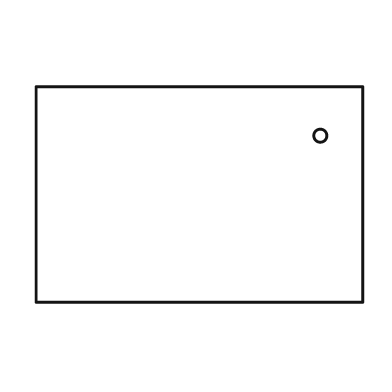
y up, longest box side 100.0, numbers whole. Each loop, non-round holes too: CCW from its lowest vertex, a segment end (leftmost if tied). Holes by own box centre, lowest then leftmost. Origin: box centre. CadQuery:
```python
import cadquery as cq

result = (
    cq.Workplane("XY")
    .moveTo(-50.0, -33.0)
    .lineTo(50.0, -33.0)
    .lineTo(50.0, 33.0)
    .lineTo(-50.0, 33.0)
    .close()
    .moveTo(37.0, 18.0)
    .circle(2.0)
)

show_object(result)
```